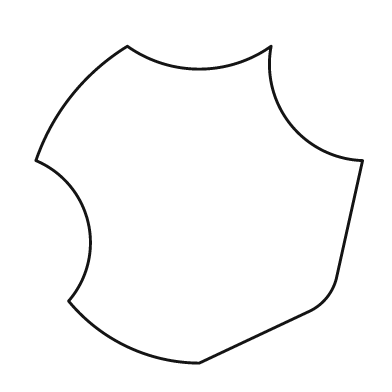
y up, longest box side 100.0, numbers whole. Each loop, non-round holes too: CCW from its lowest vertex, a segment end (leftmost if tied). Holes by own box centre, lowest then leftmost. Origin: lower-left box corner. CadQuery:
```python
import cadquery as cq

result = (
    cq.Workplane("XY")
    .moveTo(50.0, 0.0)
    .lineTo(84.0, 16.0)
    .threePointArc((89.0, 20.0), (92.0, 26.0))
    .lineTo(100.0, 62.0)
    .threePointArc((78.0, 73.0), (72.0, 97.0))
    .threePointArc((50.0, 90.0), (28.0, 97.0))
    .threePointArc((11.0, 82.0), (0.0, 62.0))
    .threePointArc((16.0, 43.0), (10.0, 19.0))
    .threePointArc((28.0, 5.0), (50.0, 0.0))
    .close()
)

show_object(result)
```